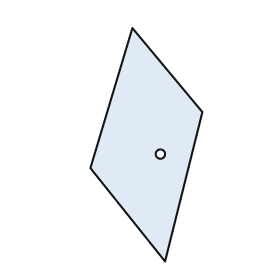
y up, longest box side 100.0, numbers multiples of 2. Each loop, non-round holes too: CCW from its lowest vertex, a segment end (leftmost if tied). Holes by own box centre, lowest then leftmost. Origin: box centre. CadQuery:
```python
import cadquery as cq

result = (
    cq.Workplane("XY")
    .moveTo(8.0, -50.0)
    .lineTo(24.0, 14.0)
    .lineTo(-6.0, 50.0)
    .lineTo(-24.0, -10.0)
    .close()
    .moveTo(6.0, -4.0)
    .circle(2.0)
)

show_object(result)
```